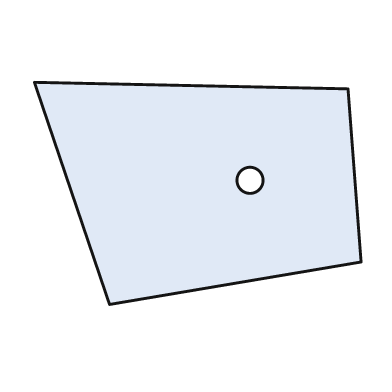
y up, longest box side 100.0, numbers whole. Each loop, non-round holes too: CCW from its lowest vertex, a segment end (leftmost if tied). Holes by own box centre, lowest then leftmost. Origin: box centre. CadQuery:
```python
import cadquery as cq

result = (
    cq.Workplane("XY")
    .moveTo(-27.0, -34.0)
    .lineTo(50.0, -21.0)
    .lineTo(46.0, 32.0)
    .lineTo(-50.0, 34.0)
    .close()
    .moveTo(16.0, 4.0)
    .circle(4.0)
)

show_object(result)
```